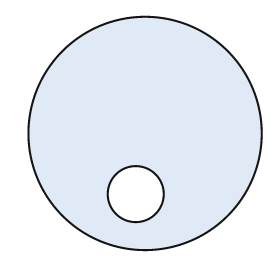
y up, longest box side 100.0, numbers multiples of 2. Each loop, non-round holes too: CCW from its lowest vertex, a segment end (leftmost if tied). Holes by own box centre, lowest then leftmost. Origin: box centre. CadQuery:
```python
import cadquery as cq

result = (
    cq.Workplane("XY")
    .moveTo(0.0, 0.0)
    .circle(50.0)
    .moveTo(-4.0, -26.0)
    .circle(12.0)
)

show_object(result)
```